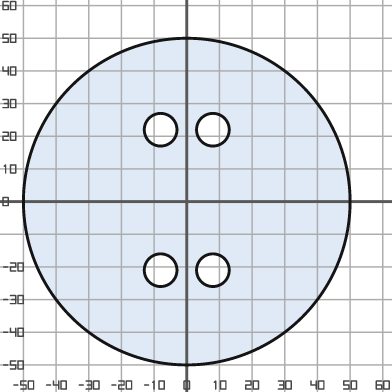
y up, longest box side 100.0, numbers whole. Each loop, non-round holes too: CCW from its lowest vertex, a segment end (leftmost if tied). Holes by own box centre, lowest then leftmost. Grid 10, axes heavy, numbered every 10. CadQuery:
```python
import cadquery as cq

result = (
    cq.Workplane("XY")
    .moveTo(0.0, 0.0)
    .circle(50.0)
    .moveTo(-8.0, -21.0)
    .circle(5.0)
    .moveTo(8.0, -21.0)
    .circle(5.0)
    .moveTo(-8.0, 22.0)
    .circle(5.0)
    .moveTo(8.0, 22.0)
    .circle(5.0)
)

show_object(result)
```